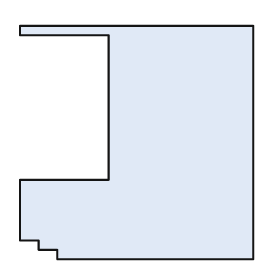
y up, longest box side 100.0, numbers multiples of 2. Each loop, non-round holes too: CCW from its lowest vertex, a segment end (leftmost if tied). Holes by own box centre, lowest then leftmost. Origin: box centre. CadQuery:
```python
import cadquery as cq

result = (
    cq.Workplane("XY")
    .moveTo(-34.0, -50.0)
    .lineTo(50.0, -50.0)
    .lineTo(50.0, 50.0)
    .lineTo(-50.0, 50.0)
    .lineTo(-50.0, 46.0)
    .lineTo(-12.0, 46.0)
    .lineTo(-12.0, -16.0)
    .lineTo(-50.0, -16.0)
    .lineTo(-50.0, -42.0)
    .lineTo(-42.0, -42.0)
    .lineTo(-42.0, -46.0)
    .lineTo(-34.0, -46.0)
    .close()
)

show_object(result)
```